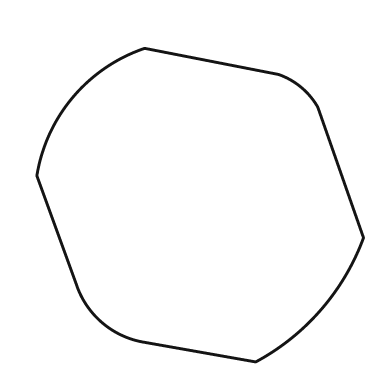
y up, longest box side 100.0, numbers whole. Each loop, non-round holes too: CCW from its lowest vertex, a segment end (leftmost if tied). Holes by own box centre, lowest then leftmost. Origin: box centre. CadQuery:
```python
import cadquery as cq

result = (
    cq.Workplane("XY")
    .moveTo(17.0, -48.0)
    .threePointArc((37.0, -32.0), (50.0, -10.0))
    .lineTo(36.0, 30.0)
    .threePointArc((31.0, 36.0), (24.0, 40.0))
    .lineTo(-17.0, 48.0)
    .threePointArc((-39.0, 33.0), (-50.0, 9.0))
    .lineTo(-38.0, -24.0)
    .threePointArc((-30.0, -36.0), (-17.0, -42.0))
    .close()
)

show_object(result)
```